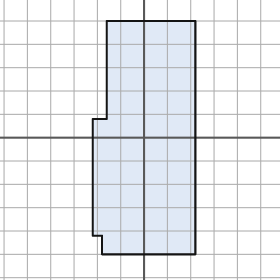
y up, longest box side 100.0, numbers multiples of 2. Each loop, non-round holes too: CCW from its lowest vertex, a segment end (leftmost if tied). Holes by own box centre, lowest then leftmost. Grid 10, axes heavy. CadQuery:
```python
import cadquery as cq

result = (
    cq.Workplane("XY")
    .moveTo(-18.0, -50.0)
    .lineTo(22.0, -50.0)
    .lineTo(22.0, 50.0)
    .lineTo(-16.0, 50.0)
    .lineTo(-16.0, 8.0)
    .lineTo(-22.0, 8.0)
    .lineTo(-22.0, -42.0)
    .lineTo(-18.0, -42.0)
    .close()
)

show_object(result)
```